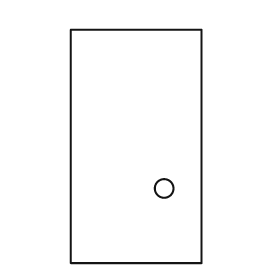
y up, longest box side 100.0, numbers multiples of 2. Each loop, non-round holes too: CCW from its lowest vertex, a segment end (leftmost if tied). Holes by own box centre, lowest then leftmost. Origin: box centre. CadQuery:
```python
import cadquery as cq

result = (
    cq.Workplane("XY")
    .moveTo(-28.0, -50.0)
    .lineTo(28.0, -50.0)
    .lineTo(28.0, 50.0)
    .lineTo(-28.0, 50.0)
    .close()
    .moveTo(12.0, -18.0)
    .circle(4.0)
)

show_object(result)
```